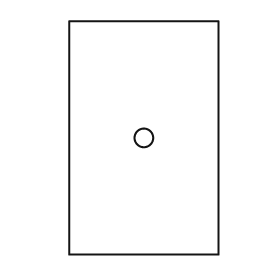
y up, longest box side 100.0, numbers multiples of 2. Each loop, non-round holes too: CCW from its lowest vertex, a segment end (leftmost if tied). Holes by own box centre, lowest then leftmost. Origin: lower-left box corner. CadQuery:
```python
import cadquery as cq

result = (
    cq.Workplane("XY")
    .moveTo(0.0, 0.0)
    .lineTo(64.0, 0.0)
    .lineTo(64.0, 100.0)
    .lineTo(0.0, 100.0)
    .close()
    .moveTo(32.0, 50.0)
    .circle(4.0)
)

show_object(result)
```